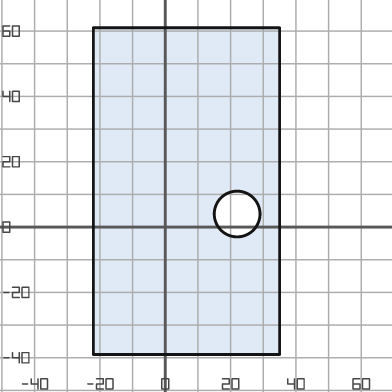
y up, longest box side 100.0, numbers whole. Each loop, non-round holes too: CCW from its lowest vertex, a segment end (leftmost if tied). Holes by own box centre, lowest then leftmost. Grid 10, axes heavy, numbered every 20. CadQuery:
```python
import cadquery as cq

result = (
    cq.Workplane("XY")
    .moveTo(-22.0, -39.0)
    .lineTo(35.0, -39.0)
    .lineTo(35.0, 61.0)
    .lineTo(-22.0, 61.0)
    .close()
    .moveTo(22.0, 4.0)
    .circle(7.0)
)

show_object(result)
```